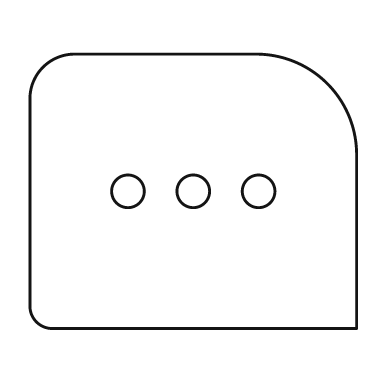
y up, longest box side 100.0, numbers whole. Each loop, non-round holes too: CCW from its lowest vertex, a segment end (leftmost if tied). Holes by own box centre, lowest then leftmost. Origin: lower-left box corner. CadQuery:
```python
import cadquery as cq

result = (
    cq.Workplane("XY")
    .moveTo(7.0, 0.0)
    .lineTo(100.0, 0.0)
    .lineTo(100.0, 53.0)
    .threePointArc((91.0, 75.0), (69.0, 84.0))
    .lineTo(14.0, 84.0)
    .threePointArc((4.0, 80.0), (0.0, 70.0))
    .lineTo(0.0, 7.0)
    .threePointArc((2.0, 2.0), (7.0, 0.0))
    .close()
    .moveTo(30.0, 42.0)
    .circle(5.0)
    .moveTo(50.0, 42.0)
    .circle(5.0)
    .moveTo(70.0, 42.0)
    .circle(5.0)
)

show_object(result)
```